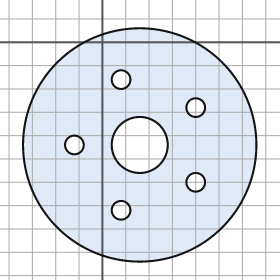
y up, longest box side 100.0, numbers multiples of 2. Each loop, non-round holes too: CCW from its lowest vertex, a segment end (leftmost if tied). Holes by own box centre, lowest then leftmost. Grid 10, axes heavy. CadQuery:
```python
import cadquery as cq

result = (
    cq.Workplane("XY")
    .moveTo(16.0, -44.0)
    .circle(50.0)
    .moveTo(8.0, -72.0)
    .circle(4.0)
    .moveTo(40.0, -60.0)
    .circle(4.0)
    .moveTo(-12.0, -44.0)
    .circle(4.0)
    .moveTo(16.0, -44.0)
    .circle(12.0)
    .moveTo(40.0, -28.0)
    .circle(4.0)
    .moveTo(8.0, -16.0)
    .circle(4.0)
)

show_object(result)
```